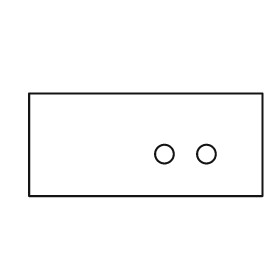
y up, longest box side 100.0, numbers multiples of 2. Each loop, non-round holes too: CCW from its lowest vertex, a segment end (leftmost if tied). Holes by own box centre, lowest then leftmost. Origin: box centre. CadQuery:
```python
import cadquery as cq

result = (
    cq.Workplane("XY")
    .moveTo(-50.0, -22.0)
    .lineTo(50.0, -22.0)
    .lineTo(50.0, 22.0)
    .lineTo(-50.0, 22.0)
    .close()
    .moveTo(8.0, -4.0)
    .circle(4.0)
    .moveTo(26.0, -4.0)
    .circle(4.0)
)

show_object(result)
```